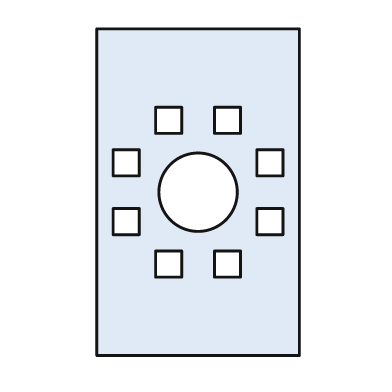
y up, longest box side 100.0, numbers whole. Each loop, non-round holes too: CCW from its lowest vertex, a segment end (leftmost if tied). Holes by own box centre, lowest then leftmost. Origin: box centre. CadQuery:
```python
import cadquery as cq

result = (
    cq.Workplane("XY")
    .moveTo(-31.0, -50.0)
    .lineTo(31.0, -50.0)
    .lineTo(31.0, 50.0)
    .lineTo(-31.0, 50.0)
    .close()
    .moveTo(-13.0, -26.0)
    .lineTo(-5.0, -26.0)
    .lineTo(-5.0, -18.0)
    .lineTo(-13.0, -18.0)
    .close()
    .moveTo(5.0, -26.0)
    .lineTo(13.0, -26.0)
    .lineTo(13.0, -18.0)
    .lineTo(5.0, -18.0)
    .close()
    .moveTo(-26.0, -13.0)
    .lineTo(-18.0, -13.0)
    .lineTo(-18.0, -5.0)
    .lineTo(-26.0, -5.0)
    .close()
    .moveTo(18.0, -13.0)
    .lineTo(26.0, -13.0)
    .lineTo(26.0, -5.0)
    .lineTo(18.0, -5.0)
    .close()
    .moveTo(0.0, 0.0)
    .circle(12.0)
    .moveTo(-26.0, 5.0)
    .lineTo(-18.0, 5.0)
    .lineTo(-18.0, 13.0)
    .lineTo(-26.0, 13.0)
    .close()
    .moveTo(18.0, 5.0)
    .lineTo(26.0, 5.0)
    .lineTo(26.0, 13.0)
    .lineTo(18.0, 13.0)
    .close()
    .moveTo(-13.0, 18.0)
    .lineTo(-5.0, 18.0)
    .lineTo(-5.0, 26.0)
    .lineTo(-13.0, 26.0)
    .close()
    .moveTo(5.0, 18.0)
    .lineTo(13.0, 18.0)
    .lineTo(13.0, 26.0)
    .lineTo(5.0, 26.0)
    .close()
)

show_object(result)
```